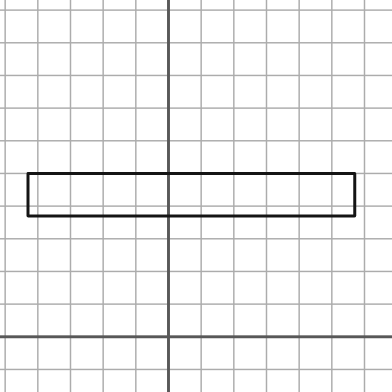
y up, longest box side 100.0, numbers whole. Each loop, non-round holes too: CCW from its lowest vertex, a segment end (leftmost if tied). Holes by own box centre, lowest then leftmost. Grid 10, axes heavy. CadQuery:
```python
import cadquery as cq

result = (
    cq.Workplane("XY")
    .moveTo(-43.0, 37.0)
    .lineTo(57.0, 37.0)
    .lineTo(57.0, 50.0)
    .lineTo(-43.0, 50.0)
    .close()
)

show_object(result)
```